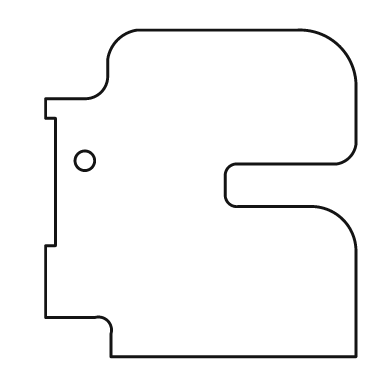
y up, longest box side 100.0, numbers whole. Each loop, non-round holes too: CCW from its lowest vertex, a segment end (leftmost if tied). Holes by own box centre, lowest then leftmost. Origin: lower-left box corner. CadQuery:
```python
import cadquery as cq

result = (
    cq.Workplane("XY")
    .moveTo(20.0, 0.0)
    .lineTo(95.0, 0.0)
    .lineTo(95.0, 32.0)
    .threePointArc((91.0, 42.0), (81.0, 46.0))
    .lineTo(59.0, 46.0)
    .threePointArc((56.0, 47.0), (55.0, 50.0))
    .lineTo(55.0, 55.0)
    .threePointArc((56.0, 58.0), (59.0, 59.0))
    .lineTo(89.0, 59.0)
    .threePointArc((93.0, 61.0), (95.0, 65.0))
    .lineTo(95.0, 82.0)
    .threePointArc((90.0, 95.0), (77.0, 100.0))
    .lineTo(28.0, 100.0)
    .threePointArc((22.0, 97.0), (19.0, 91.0))
    .lineTo(19.0, 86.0)
    .threePointArc((17.0, 81.0), (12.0, 79.0))
    .lineTo(0.0, 79.0)
    .lineTo(0.0, 73.0)
    .lineTo(3.0, 73.0)
    .lineTo(3.0, 34.0)
    .lineTo(0.0, 34.0)
    .lineTo(0.0, 12.0)
    .lineTo(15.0, 12.0)
    .threePointArc((19.0, 11.0), (20.0, 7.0))
    .close()
    .moveTo(12.0, 60.0)
    .circle(3.0)
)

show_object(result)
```